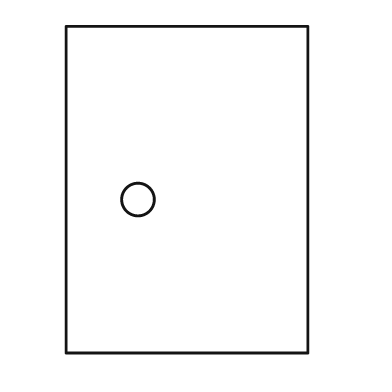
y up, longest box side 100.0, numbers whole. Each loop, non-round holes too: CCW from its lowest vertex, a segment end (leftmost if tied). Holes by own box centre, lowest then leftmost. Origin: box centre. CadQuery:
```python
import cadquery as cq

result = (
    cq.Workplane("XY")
    .moveTo(-37.0, -50.0)
    .lineTo(37.0, -50.0)
    .lineTo(37.0, 50.0)
    .lineTo(-37.0, 50.0)
    .close()
    .moveTo(-15.0, -3.0)
    .circle(5.0)
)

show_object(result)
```